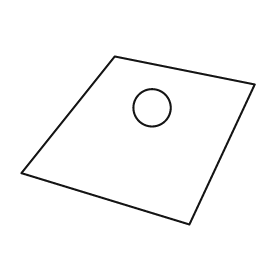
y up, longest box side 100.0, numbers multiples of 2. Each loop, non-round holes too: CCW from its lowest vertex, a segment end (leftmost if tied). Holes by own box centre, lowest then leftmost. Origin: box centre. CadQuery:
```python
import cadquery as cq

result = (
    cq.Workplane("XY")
    .moveTo(22.0, -36.0)
    .lineTo(50.0, 24.0)
    .lineTo(-10.0, 36.0)
    .lineTo(-50.0, -14.0)
    .close()
    .moveTo(6.0, 14.0)
    .circle(8.0)
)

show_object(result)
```